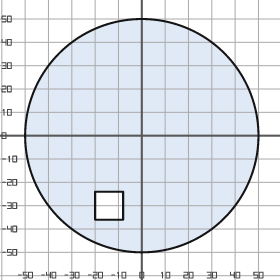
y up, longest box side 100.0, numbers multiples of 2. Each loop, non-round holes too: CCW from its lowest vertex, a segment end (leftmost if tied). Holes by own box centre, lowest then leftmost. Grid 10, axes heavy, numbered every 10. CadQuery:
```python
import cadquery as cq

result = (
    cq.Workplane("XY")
    .moveTo(0.0, 0.0)
    .circle(50.0)
    .moveTo(-20.0, -36.0)
    .lineTo(-8.0, -36.0)
    .lineTo(-8.0, -24.0)
    .lineTo(-20.0, -24.0)
    .close()
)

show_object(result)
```